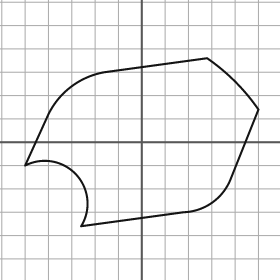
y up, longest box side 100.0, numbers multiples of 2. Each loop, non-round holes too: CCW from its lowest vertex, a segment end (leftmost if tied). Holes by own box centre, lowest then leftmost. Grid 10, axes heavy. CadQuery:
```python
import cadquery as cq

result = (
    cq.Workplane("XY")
    .moveTo(-26.0, -36.0)
    .lineTo(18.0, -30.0)
    .threePointArc((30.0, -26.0), (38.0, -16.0))
    .lineTo(50.0, 14.0)
    .threePointArc((40.0, 26.0), (28.0, 36.0))
    .lineTo(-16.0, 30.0)
    .threePointArc((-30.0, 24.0), (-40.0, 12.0))
    .lineTo(-50.0, -10.0)
    .threePointArc((-28.0, -14.0), (-26.0, -36.0))
    .close()
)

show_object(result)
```